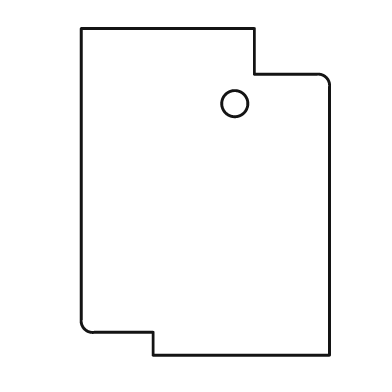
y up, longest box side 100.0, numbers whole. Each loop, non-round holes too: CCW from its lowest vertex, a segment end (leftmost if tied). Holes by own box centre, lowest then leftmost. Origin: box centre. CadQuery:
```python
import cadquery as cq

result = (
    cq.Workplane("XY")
    .moveTo(-16.0, -50.0)
    .lineTo(38.0, -50.0)
    .lineTo(38.0, 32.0)
    .threePointArc((37.0, 35.0), (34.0, 36.0))
    .lineTo(15.0, 36.0)
    .lineTo(15.0, 50.0)
    .lineTo(-38.0, 50.0)
    .lineTo(-38.0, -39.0)
    .threePointArc((-37.0, -42.0), (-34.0, -43.0))
    .lineTo(-16.0, -43.0)
    .close()
    .moveTo(9.0, 27.0)
    .circle(4.0)
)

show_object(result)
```